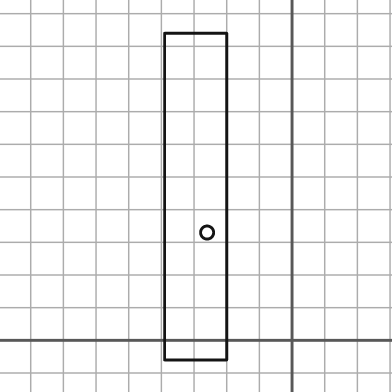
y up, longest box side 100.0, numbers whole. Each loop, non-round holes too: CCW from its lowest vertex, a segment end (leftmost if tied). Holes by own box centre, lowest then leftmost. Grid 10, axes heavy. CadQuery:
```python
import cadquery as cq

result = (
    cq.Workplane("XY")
    .moveTo(-39.0, -6.0)
    .lineTo(-20.0, -6.0)
    .lineTo(-20.0, 94.0)
    .lineTo(-39.0, 94.0)
    .close()
    .moveTo(-26.0, 33.0)
    .circle(2.0)
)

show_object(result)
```